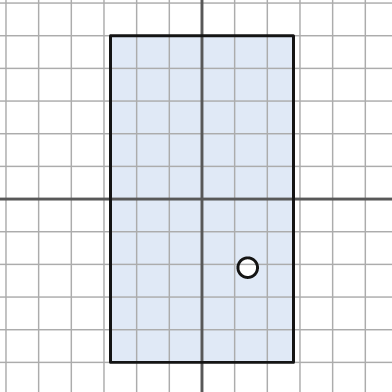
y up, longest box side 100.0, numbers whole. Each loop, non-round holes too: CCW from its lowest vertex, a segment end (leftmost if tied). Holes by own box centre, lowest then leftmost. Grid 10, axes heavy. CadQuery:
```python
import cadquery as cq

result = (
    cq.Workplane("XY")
    .moveTo(-28.0, -50.0)
    .lineTo(28.0, -50.0)
    .lineTo(28.0, 50.0)
    .lineTo(-28.0, 50.0)
    .close()
    .moveTo(14.0, -21.0)
    .circle(3.0)
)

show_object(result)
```